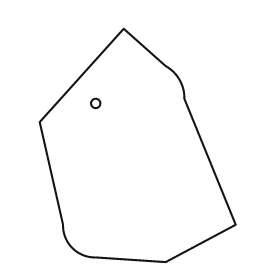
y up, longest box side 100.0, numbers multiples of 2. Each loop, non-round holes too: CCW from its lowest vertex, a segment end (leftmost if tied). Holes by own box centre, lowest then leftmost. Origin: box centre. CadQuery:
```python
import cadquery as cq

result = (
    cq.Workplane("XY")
    .moveTo(12.0, -50.0)
    .lineTo(42.0, -34.0)
    .lineTo(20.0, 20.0)
    .threePointArc((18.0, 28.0), (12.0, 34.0))
    .lineTo(-6.0, 50.0)
    .lineTo(-42.0, 10.0)
    .lineTo(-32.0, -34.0)
    .threePointArc((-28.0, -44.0), (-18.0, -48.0))
    .close()
    .moveTo(-18.0, 18.0)
    .circle(2.0)
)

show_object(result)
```